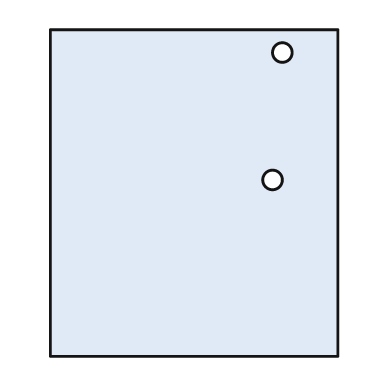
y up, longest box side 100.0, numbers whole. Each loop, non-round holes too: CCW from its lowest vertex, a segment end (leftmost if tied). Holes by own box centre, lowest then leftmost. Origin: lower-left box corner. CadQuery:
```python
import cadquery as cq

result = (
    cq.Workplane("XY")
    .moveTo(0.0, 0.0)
    .lineTo(88.0, 0.0)
    .lineTo(88.0, 100.0)
    .lineTo(0.0, 100.0)
    .close()
    .moveTo(68.0, 54.0)
    .circle(3.0)
    .moveTo(71.0, 93.0)
    .circle(3.0)
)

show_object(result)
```